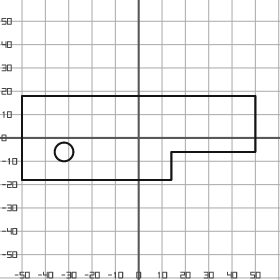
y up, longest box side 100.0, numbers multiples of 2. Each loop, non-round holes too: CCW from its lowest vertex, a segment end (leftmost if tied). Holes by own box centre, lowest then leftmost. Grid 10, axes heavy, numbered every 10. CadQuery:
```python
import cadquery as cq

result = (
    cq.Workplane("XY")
    .moveTo(-50.0, -18.0)
    .lineTo(14.0, -18.0)
    .lineTo(14.0, -6.0)
    .lineTo(50.0, -6.0)
    .lineTo(50.0, 18.0)
    .lineTo(-50.0, 18.0)
    .close()
    .moveTo(-32.0, -6.0)
    .circle(4.0)
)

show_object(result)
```